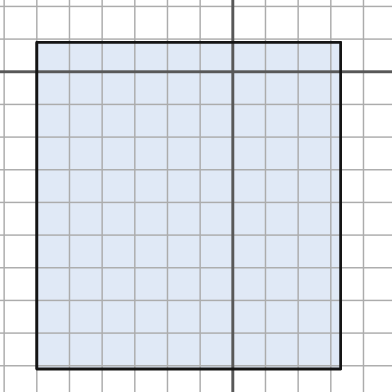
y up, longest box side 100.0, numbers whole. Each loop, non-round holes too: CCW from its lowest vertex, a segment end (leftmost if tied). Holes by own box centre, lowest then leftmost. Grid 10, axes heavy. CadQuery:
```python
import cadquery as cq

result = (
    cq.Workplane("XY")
    .moveTo(-60.0, -91.0)
    .lineTo(33.0, -91.0)
    .lineTo(33.0, 9.0)
    .lineTo(-60.0, 9.0)
    .close()
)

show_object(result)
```